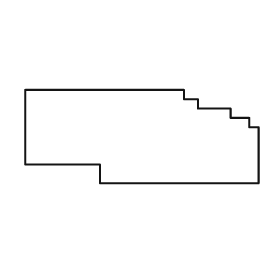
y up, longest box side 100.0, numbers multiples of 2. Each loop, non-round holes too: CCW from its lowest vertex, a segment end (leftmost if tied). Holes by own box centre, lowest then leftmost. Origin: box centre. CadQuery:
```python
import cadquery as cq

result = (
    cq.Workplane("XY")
    .moveTo(-18.0, -20.0)
    .lineTo(50.0, -20.0)
    .lineTo(50.0, 4.0)
    .lineTo(46.0, 4.0)
    .lineTo(46.0, 8.0)
    .lineTo(38.0, 8.0)
    .lineTo(38.0, 12.0)
    .lineTo(24.0, 12.0)
    .lineTo(24.0, 16.0)
    .lineTo(18.0, 16.0)
    .lineTo(18.0, 20.0)
    .lineTo(-50.0, 20.0)
    .lineTo(-50.0, -12.0)
    .lineTo(-18.0, -12.0)
    .close()
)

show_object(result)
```